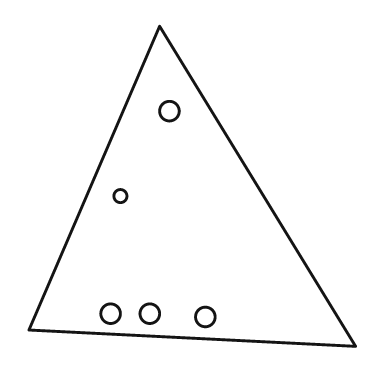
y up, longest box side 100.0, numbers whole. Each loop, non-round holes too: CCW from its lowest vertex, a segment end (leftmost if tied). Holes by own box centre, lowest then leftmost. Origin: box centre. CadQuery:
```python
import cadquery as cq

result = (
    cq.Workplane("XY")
    .moveTo(50.0, -49.0)
    .lineTo(-10.0, 49.0)
    .lineTo(-50.0, -44.0)
    .close()
    .moveTo(4.0, -40.0)
    .circle(3.0)
    .moveTo(-25.0, -39.0)
    .circle(3.0)
    .moveTo(-13.0, -39.0)
    .circle(3.0)
    .moveTo(-22.0, -3.0)
    .circle(2.0)
    .moveTo(-7.0, 23.0)
    .circle(3.0)
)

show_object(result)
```